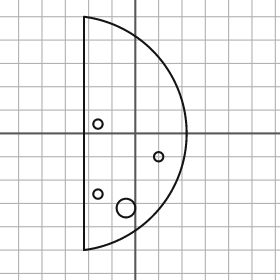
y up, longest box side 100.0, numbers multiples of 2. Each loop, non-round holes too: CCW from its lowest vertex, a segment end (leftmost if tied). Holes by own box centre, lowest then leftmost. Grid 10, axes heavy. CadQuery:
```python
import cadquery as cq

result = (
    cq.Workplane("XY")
    .moveTo(-22.0, -50.0)
    .threePointArc((22.0, 0.0), (-22.0, 50.0))
    .close()
    .moveTo(-4.0, -32.0)
    .circle(4.0)
    .moveTo(-16.0, -26.0)
    .circle(2.0)
    .moveTo(10.0, -10.0)
    .circle(2.0)
    .moveTo(-16.0, 4.0)
    .circle(2.0)
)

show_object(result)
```